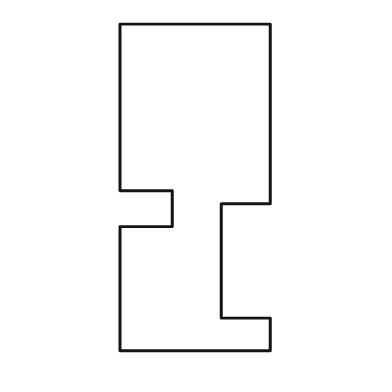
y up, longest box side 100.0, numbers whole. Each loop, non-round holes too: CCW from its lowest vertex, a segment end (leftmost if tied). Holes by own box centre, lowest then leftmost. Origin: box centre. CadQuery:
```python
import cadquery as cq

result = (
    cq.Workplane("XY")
    .moveTo(-23.0, -50.0)
    .lineTo(23.0, -50.0)
    .lineTo(23.0, -40.0)
    .lineTo(8.0, -40.0)
    .lineTo(8.0, -5.0)
    .lineTo(23.0, -5.0)
    .lineTo(23.0, 50.0)
    .lineTo(-23.0, 50.0)
    .lineTo(-23.0, -1.0)
    .lineTo(-7.0, -1.0)
    .lineTo(-7.0, -12.0)
    .lineTo(-23.0, -12.0)
    .close()
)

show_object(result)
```